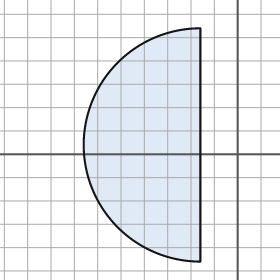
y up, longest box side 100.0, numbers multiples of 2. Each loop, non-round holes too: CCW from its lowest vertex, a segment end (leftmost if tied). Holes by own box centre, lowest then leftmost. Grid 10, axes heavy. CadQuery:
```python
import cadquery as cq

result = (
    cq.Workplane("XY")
    .moveTo(-16.0, -46.0)
    .lineTo(-16.0, 54.0)
    .threePointArc((-66.0, 4.0), (-16.0, -46.0))
    .close()
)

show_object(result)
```